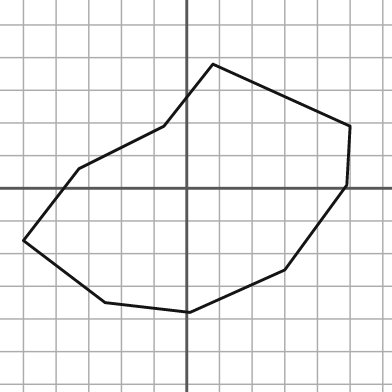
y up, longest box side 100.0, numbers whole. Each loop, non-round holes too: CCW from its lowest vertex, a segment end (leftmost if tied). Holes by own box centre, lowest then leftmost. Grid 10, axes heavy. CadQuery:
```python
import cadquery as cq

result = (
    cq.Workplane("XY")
    .moveTo(1.0, -38.0)
    .lineTo(30.0, -25.0)
    .lineTo(49.0, 1.0)
    .lineTo(50.0, 19.0)
    .lineTo(8.0, 38.0)
    .lineTo(-7.0, 19.0)
    .lineTo(-33.0, 6.0)
    .lineTo(-50.0, -16.0)
    .lineTo(-25.0, -35.0)
    .close()
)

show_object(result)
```